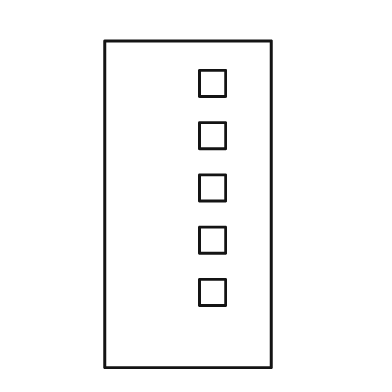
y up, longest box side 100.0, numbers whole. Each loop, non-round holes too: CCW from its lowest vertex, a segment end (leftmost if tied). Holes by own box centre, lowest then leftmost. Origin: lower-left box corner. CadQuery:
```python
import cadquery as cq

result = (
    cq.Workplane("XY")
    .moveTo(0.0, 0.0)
    .lineTo(51.0, 0.0)
    .lineTo(51.0, 100.0)
    .lineTo(0.0, 100.0)
    .close()
    .moveTo(29.0, 19.0)
    .lineTo(37.0, 19.0)
    .lineTo(37.0, 27.0)
    .lineTo(29.0, 27.0)
    .close()
    .moveTo(29.0, 35.0)
    .lineTo(37.0, 35.0)
    .lineTo(37.0, 43.0)
    .lineTo(29.0, 43.0)
    .close()
    .moveTo(29.0, 51.0)
    .lineTo(37.0, 51.0)
    .lineTo(37.0, 59.0)
    .lineTo(29.0, 59.0)
    .close()
    .moveTo(29.0, 67.0)
    .lineTo(37.0, 67.0)
    .lineTo(37.0, 75.0)
    .lineTo(29.0, 75.0)
    .close()
    .moveTo(29.0, 83.0)
    .lineTo(37.0, 83.0)
    .lineTo(37.0, 91.0)
    .lineTo(29.0, 91.0)
    .close()
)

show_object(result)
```